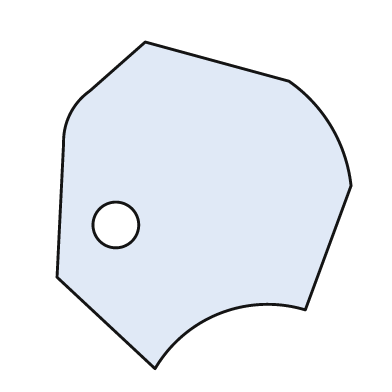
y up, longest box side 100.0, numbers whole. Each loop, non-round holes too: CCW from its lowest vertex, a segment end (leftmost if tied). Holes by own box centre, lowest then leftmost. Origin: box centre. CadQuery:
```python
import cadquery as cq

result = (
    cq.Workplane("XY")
    .moveTo(-15.0, -50.0)
    .threePointArc((5.0, -33.0), (31.0, -32.0))
    .lineTo(45.0, 6.0)
    .threePointArc((39.0, 24.0), (26.0, 38.0))
    .lineTo(-18.0, 50.0)
    .lineTo(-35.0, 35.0)
    .threePointArc((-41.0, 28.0), (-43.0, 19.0))
    .lineTo(-45.0, -22.0)
    .close()
    .moveTo(-27.0, -6.0)
    .circle(7.0)
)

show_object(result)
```